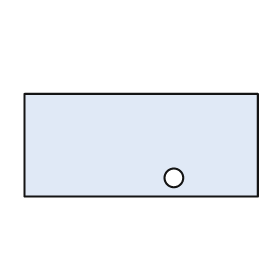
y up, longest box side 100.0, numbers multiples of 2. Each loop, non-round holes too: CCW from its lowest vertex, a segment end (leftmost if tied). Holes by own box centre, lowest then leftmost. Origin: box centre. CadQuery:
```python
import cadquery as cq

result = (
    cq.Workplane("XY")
    .moveTo(-50.0, -22.0)
    .lineTo(50.0, -22.0)
    .lineTo(50.0, 22.0)
    .lineTo(-50.0, 22.0)
    .close()
    .moveTo(14.0, -14.0)
    .circle(4.0)
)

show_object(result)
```